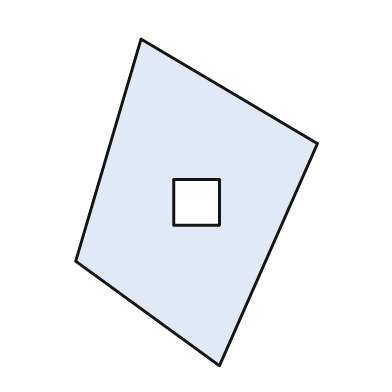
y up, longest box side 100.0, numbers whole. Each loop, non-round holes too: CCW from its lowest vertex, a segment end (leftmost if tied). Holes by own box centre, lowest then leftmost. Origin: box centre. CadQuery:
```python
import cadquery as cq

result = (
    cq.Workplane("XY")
    .moveTo(7.0, -50.0)
    .lineTo(37.0, 18.0)
    .lineTo(-17.0, 50.0)
    .lineTo(-37.0, -18.0)
    .close()
    .moveTo(-7.0, -7.0)
    .lineTo(7.0, -7.0)
    .lineTo(7.0, 7.0)
    .lineTo(-7.0, 7.0)
    .close()
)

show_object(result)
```